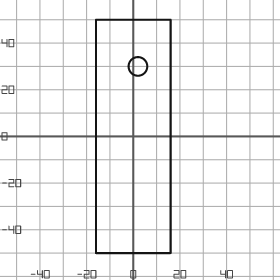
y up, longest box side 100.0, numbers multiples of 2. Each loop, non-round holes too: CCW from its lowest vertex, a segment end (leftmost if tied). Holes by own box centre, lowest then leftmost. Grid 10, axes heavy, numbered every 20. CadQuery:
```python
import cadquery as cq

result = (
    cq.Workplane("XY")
    .moveTo(-16.0, -50.0)
    .lineTo(16.0, -50.0)
    .lineTo(16.0, 50.0)
    .lineTo(-16.0, 50.0)
    .close()
    .moveTo(2.0, 30.0)
    .circle(4.0)
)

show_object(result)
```